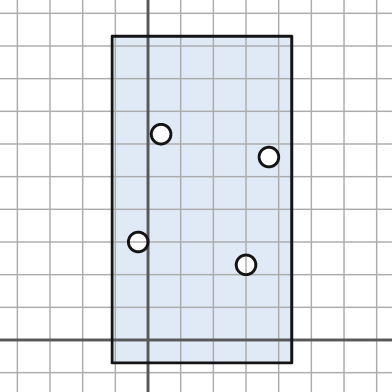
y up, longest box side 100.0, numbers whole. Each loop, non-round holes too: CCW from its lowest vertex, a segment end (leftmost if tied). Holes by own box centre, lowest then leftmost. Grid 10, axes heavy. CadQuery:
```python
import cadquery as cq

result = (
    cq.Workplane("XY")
    .moveTo(-11.0, -7.0)
    .lineTo(44.0, -7.0)
    .lineTo(44.0, 93.0)
    .lineTo(-11.0, 93.0)
    .close()
    .moveTo(30.0, 23.0)
    .circle(3.0)
    .moveTo(-3.0, 30.0)
    .circle(3.0)
    .moveTo(37.0, 56.0)
    .circle(3.0)
    .moveTo(4.0, 63.0)
    .circle(3.0)
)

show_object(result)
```